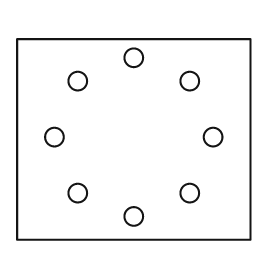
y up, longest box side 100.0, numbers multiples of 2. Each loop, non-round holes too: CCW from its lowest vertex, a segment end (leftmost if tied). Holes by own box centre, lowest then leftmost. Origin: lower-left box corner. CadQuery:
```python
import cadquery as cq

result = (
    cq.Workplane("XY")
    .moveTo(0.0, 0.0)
    .lineTo(100.0, 0.0)
    .lineTo(100.0, 86.0)
    .lineTo(0.0, 86.0)
    .close()
    .moveTo(50.0, 10.0)
    .circle(4.0)
    .moveTo(26.0, 20.0)
    .circle(4.0)
    .moveTo(74.0, 20.0)
    .circle(4.0)
    .moveTo(16.0, 44.0)
    .circle(4.0)
    .moveTo(84.0, 44.0)
    .circle(4.0)
    .moveTo(26.0, 68.0)
    .circle(4.0)
    .moveTo(74.0, 68.0)
    .circle(4.0)
    .moveTo(50.0, 78.0)
    .circle(4.0)
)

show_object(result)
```